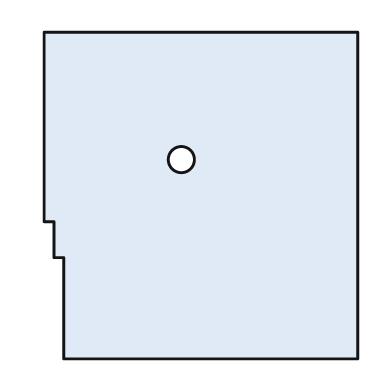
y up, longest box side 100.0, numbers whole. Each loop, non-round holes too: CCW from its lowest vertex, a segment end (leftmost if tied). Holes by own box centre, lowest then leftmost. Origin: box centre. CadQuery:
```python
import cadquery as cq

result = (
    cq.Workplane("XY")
    .moveTo(-42.0, -50.0)
    .lineTo(48.0, -50.0)
    .lineTo(48.0, 50.0)
    .lineTo(-48.0, 50.0)
    .lineTo(-48.0, -8.0)
    .lineTo(-45.0, -8.0)
    .lineTo(-45.0, -19.0)
    .lineTo(-42.0, -19.0)
    .close()
    .moveTo(-6.0, 11.0)
    .circle(4.0)
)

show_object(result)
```